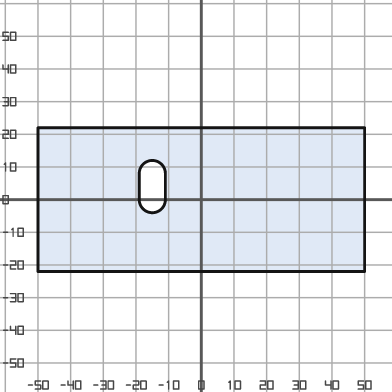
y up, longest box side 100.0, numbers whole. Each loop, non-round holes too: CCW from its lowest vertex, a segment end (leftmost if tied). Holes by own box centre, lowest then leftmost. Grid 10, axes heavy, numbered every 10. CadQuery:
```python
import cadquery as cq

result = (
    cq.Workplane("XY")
    .moveTo(-50.0, -22.0)
    .lineTo(50.0, -22.0)
    .lineTo(50.0, 22.0)
    .lineTo(-50.0, 22.0)
    .close()
    .moveTo(-19.0, 0.0)
    .threePointArc((-15.0, -4.0), (-11.0, 0.0))
    .lineTo(-11.0, 8.0)
    .threePointArc((-15.0, 12.0), (-19.0, 8.0))
    .close()
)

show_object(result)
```